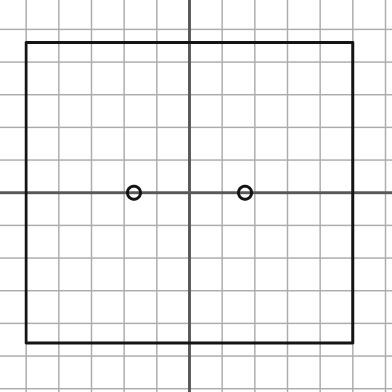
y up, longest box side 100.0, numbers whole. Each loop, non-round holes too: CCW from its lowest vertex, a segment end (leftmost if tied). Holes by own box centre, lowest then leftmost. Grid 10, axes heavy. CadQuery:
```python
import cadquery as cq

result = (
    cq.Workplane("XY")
    .moveTo(-50.0, -46.0)
    .lineTo(50.0, -46.0)
    .lineTo(50.0, 46.0)
    .lineTo(-50.0, 46.0)
    .close()
    .moveTo(-17.0, 0.0)
    .circle(2.0)
    .moveTo(17.0, 0.0)
    .circle(2.0)
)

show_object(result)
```